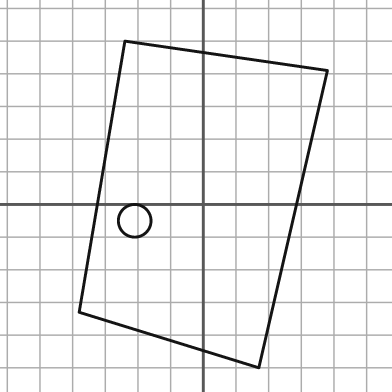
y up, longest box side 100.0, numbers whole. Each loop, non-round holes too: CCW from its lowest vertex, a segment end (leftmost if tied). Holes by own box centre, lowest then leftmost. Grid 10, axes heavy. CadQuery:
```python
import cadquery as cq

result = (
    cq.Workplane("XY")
    .moveTo(17.0, -50.0)
    .lineTo(38.0, 41.0)
    .lineTo(-24.0, 50.0)
    .lineTo(-38.0, -33.0)
    .close()
    .moveTo(-21.0, -5.0)
    .circle(5.0)
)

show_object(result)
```